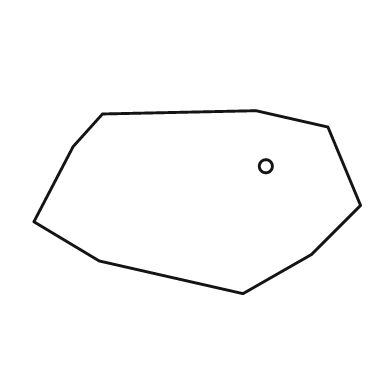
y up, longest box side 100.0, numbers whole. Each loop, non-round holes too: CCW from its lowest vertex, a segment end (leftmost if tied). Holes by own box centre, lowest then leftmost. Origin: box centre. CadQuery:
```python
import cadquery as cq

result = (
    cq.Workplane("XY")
    .moveTo(14.0, -28.0)
    .lineTo(35.0, -16.0)
    .lineTo(50.0, -1.0)
    .lineTo(40.0, 23.0)
    .lineTo(18.0, 28.0)
    .lineTo(-29.0, 27.0)
    .lineTo(-38.0, 17.0)
    .lineTo(-50.0, -6.0)
    .lineTo(-30.0, -18.0)
    .close()
    .moveTo(21.0, 11.0)
    .circle(2.0)
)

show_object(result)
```